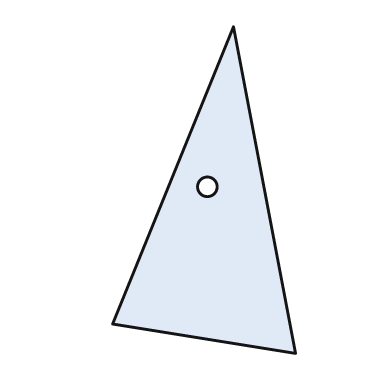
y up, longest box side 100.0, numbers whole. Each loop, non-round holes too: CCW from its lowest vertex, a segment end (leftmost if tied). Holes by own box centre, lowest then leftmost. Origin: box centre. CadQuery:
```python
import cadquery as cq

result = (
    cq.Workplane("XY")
    .moveTo(28.0, -50.0)
    .lineTo(9.0, 50.0)
    .lineTo(-28.0, -41.0)
    .close()
    .moveTo(1.0, 1.0)
    .circle(3.0)
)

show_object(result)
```